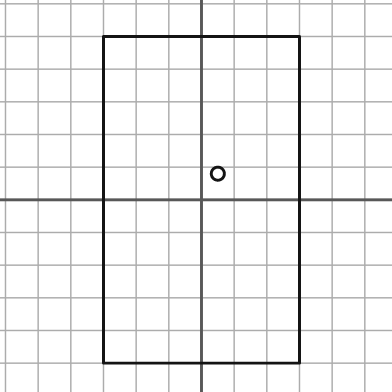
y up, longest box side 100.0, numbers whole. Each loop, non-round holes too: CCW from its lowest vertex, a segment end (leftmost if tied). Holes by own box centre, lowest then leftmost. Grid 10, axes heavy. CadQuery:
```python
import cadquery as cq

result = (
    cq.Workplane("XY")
    .moveTo(-30.0, -50.0)
    .lineTo(30.0, -50.0)
    .lineTo(30.0, 50.0)
    .lineTo(-30.0, 50.0)
    .close()
    .moveTo(5.0, 8.0)
    .circle(2.0)
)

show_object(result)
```